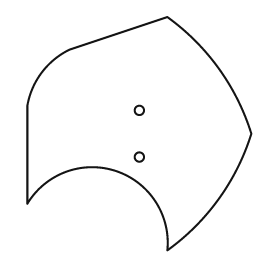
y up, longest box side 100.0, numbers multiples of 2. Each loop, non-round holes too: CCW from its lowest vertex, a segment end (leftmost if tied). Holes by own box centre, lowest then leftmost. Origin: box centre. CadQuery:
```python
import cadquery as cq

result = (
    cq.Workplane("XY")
    .moveTo(12.0, -50.0)
    .threePointArc((34.0, -28.0), (48.0, 0.0))
    .threePointArc((34.0, 28.0), (12.0, 50.0))
    .lineTo(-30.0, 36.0)
    .threePointArc((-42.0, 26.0), (-48.0, 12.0))
    .lineTo(-48.0, -30.0)
    .threePointArc((-10.0, -16.0), (12.0, -50.0))
    .close()
    .moveTo(0.0, -10.0)
    .circle(2.0)
    .moveTo(0.0, 10.0)
    .circle(2.0)
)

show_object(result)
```